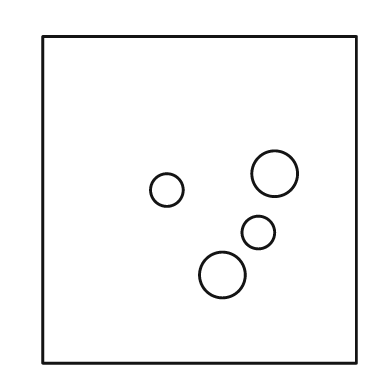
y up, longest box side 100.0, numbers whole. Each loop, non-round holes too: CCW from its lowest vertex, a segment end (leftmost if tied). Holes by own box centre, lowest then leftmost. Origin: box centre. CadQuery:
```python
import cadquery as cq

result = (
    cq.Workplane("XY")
    .moveTo(-48.0, -50.0)
    .lineTo(48.0, -50.0)
    .lineTo(48.0, 50.0)
    .lineTo(-48.0, 50.0)
    .close()
    .moveTo(7.0, -23.0)
    .circle(7.0)
    .moveTo(18.0, -10.0)
    .circle(5.0)
    .moveTo(-10.0, 3.0)
    .circle(5.0)
    .moveTo(23.0, 8.0)
    .circle(7.0)
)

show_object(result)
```